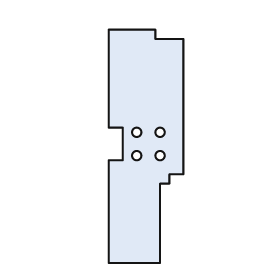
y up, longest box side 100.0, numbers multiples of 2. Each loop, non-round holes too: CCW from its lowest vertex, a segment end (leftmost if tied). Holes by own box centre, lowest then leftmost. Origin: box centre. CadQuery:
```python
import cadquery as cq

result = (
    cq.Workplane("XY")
    .moveTo(-16.0, -50.0)
    .lineTo(6.0, -50.0)
    .lineTo(6.0, -16.0)
    .lineTo(10.0, -16.0)
    .lineTo(10.0, -12.0)
    .lineTo(16.0, -12.0)
    .lineTo(16.0, 46.0)
    .lineTo(4.0, 46.0)
    .lineTo(4.0, 50.0)
    .lineTo(-16.0, 50.0)
    .lineTo(-16.0, 8.0)
    .lineTo(-10.0, 8.0)
    .lineTo(-10.0, -6.0)
    .lineTo(-16.0, -6.0)
    .close()
    .moveTo(-4.0, -4.0)
    .circle(2.0)
    .moveTo(6.0, -4.0)
    .circle(2.0)
    .moveTo(-4.0, 6.0)
    .circle(2.0)
    .moveTo(6.0, 6.0)
    .circle(2.0)
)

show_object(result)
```